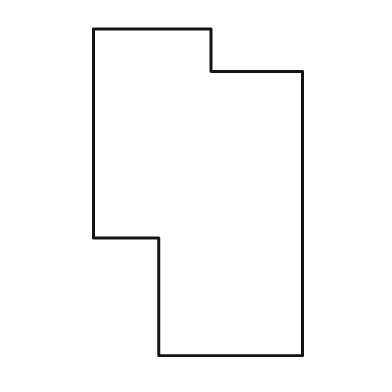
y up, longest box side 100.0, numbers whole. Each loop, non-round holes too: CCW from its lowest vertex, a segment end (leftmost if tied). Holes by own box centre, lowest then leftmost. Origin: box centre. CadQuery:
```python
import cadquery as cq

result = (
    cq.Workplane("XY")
    .moveTo(-12.0, -50.0)
    .lineTo(32.0, -50.0)
    .lineTo(32.0, 37.0)
    .lineTo(4.0, 37.0)
    .lineTo(4.0, 50.0)
    .lineTo(-32.0, 50.0)
    .lineTo(-32.0, -14.0)
    .lineTo(-12.0, -14.0)
    .close()
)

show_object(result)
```